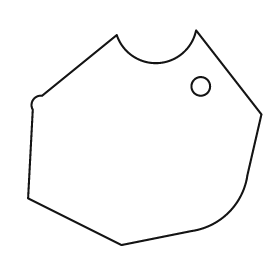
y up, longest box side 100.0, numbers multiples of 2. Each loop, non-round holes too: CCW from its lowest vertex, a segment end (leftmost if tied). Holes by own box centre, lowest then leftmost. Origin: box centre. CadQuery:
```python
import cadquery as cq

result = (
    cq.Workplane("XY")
    .moveTo(-10.0, -46.0)
    .lineTo(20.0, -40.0)
    .threePointArc((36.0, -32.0), (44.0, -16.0))
    .lineTo(50.0, 10.0)
    .lineTo(22.0, 46.0)
    .threePointArc((6.0, 32.0), (-12.0, 44.0))
    .lineTo(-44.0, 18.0)
    .threePointArc((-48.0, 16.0), (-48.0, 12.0))
    .lineTo(-50.0, -26.0)
    .close()
    .moveTo(24.0, 22.0)
    .circle(4.0)
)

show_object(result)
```